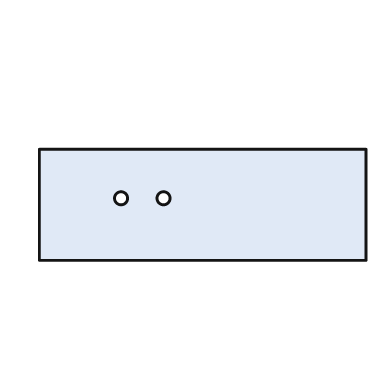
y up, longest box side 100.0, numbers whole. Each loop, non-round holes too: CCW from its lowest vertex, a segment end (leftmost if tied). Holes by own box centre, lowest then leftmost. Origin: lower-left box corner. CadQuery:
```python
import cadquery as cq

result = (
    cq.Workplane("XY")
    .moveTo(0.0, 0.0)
    .lineTo(100.0, 0.0)
    .lineTo(100.0, 34.0)
    .lineTo(0.0, 34.0)
    .close()
    .moveTo(25.0, 19.0)
    .circle(2.0)
    .moveTo(38.0, 19.0)
    .circle(2.0)
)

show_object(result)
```